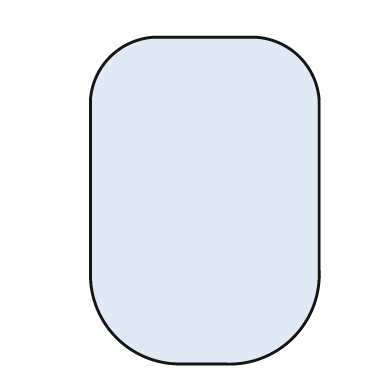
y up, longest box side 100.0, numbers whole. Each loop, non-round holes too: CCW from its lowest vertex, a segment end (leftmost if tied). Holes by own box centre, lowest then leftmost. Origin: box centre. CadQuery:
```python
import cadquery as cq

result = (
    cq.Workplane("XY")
    .moveTo(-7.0, -50.0)
    .lineTo(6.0, -50.0)
    .threePointArc((27.0, -42.0), (35.0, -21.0))
    .lineTo(35.0, 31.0)
    .threePointArc((29.0, 44.0), (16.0, 50.0))
    .lineTo(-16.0, 50.0)
    .threePointArc((-29.0, 44.0), (-35.0, 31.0))
    .lineTo(-35.0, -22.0)
    .threePointArc((-27.0, -42.0), (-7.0, -50.0))
    .close()
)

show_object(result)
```